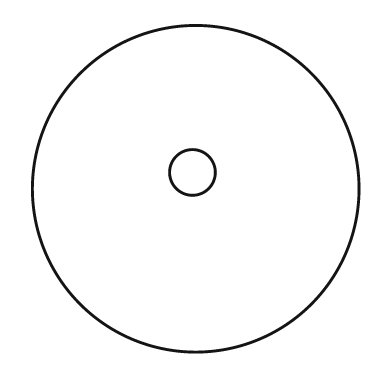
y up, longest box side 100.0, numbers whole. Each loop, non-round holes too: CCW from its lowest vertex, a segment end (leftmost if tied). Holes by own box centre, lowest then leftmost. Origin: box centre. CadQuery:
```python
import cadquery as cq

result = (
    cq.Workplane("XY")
    .moveTo(0.0, 0.0)
    .circle(50.0)
    .moveTo(-1.0, 5.0)
    .circle(7.0)
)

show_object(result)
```